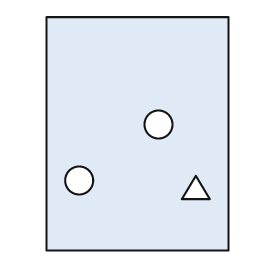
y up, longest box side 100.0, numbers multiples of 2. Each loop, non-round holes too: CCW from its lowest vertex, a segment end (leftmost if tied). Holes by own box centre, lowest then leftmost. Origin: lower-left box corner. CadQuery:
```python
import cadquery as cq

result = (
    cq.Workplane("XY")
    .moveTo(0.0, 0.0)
    .lineTo(78.0, 0.0)
    .lineTo(78.0, 100.0)
    .lineTo(0.0, 100.0)
    .close()
    .moveTo(58.0, 22.0)
    .lineTo(70.0, 22.0)
    .lineTo(64.0, 32.0)
    .close()
    .moveTo(14.0, 30.0)
    .circle(6.0)
    .moveTo(48.0, 54.0)
    .circle(6.0)
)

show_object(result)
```